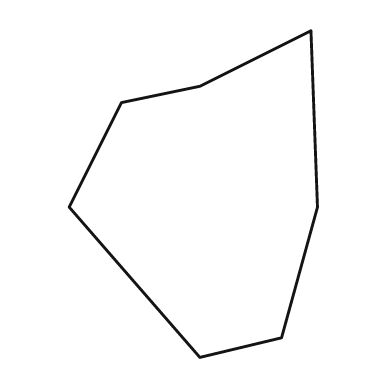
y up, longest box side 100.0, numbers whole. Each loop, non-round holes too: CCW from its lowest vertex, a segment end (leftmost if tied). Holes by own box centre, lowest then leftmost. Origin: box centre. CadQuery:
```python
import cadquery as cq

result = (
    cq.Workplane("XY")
    .moveTo(2.0, -50.0)
    .lineTo(27.0, -44.0)
    .lineTo(38.0, -4.0)
    .lineTo(36.0, 50.0)
    .lineTo(2.0, 33.0)
    .lineTo(-22.0, 28.0)
    .lineTo(-38.0, -4.0)
    .close()
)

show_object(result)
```